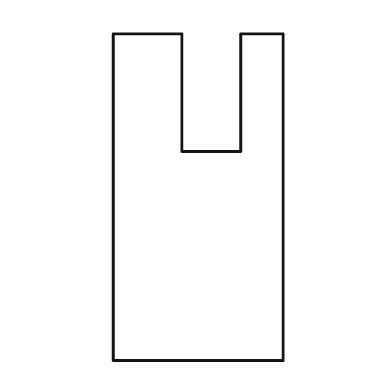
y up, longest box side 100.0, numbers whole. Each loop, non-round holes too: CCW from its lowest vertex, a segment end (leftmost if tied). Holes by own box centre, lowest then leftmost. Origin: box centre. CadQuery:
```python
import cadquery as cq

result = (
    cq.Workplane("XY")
    .moveTo(-26.0, -50.0)
    .lineTo(26.0, -50.0)
    .lineTo(26.0, 50.0)
    .lineTo(13.0, 50.0)
    .lineTo(13.0, 14.0)
    .lineTo(-5.0, 14.0)
    .lineTo(-5.0, 50.0)
    .lineTo(-26.0, 50.0)
    .close()
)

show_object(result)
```